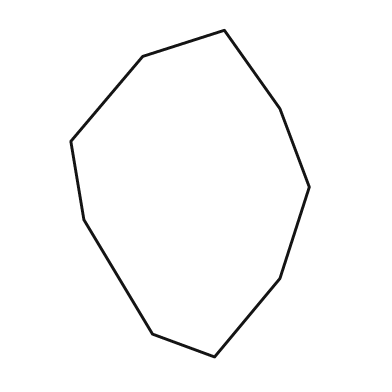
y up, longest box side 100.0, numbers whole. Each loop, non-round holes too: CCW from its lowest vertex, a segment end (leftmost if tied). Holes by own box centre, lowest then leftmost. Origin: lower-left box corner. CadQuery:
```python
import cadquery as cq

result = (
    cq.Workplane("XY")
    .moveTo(44.0, 0.0)
    .lineTo(64.0, 24.0)
    .lineTo(73.0, 52.0)
    .lineTo(64.0, 76.0)
    .lineTo(47.0, 100.0)
    .lineTo(22.0, 92.0)
    .lineTo(0.0, 66.0)
    .lineTo(4.0, 42.0)
    .lineTo(25.0, 7.0)
    .close()
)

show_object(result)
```